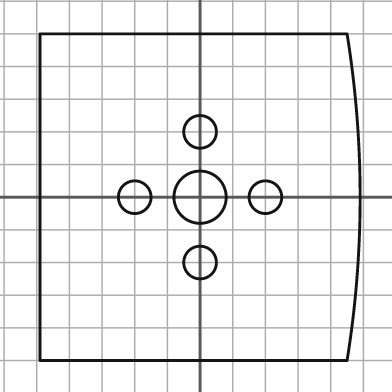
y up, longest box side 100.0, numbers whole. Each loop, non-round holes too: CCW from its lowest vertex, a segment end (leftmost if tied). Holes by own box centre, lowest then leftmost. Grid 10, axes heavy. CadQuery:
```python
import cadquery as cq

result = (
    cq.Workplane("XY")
    .moveTo(-49.0, -50.0)
    .lineTo(45.0, -50.0)
    .threePointArc((49.0, 0.0), (45.0, 50.0))
    .lineTo(-49.0, 50.0)
    .close()
    .moveTo(0.0, -20.0)
    .circle(5.0)
    .moveTo(-20.0, 0.0)
    .circle(5.0)
    .moveTo(0.0, 0.0)
    .circle(8.0)
    .moveTo(20.0, 0.0)
    .circle(5.0)
    .moveTo(0.0, 20.0)
    .circle(5.0)
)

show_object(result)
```